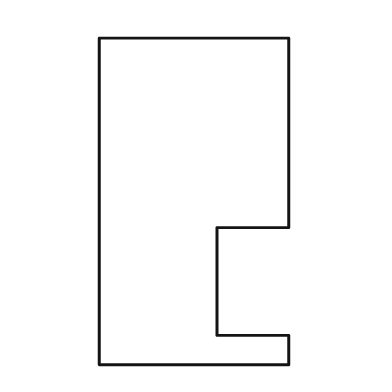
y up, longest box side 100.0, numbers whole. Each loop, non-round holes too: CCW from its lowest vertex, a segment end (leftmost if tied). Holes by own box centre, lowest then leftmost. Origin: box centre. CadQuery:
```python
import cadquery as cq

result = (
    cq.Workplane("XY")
    .moveTo(-29.0, -50.0)
    .lineTo(29.0, -50.0)
    .lineTo(29.0, -41.0)
    .lineTo(7.0, -41.0)
    .lineTo(7.0, -8.0)
    .lineTo(29.0, -8.0)
    .lineTo(29.0, 50.0)
    .lineTo(-29.0, 50.0)
    .close()
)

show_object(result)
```